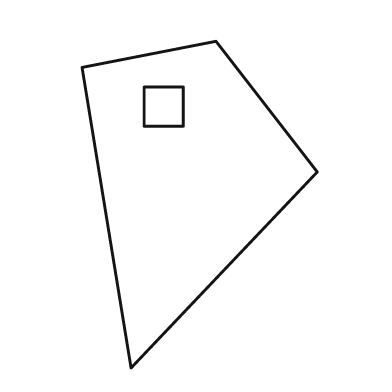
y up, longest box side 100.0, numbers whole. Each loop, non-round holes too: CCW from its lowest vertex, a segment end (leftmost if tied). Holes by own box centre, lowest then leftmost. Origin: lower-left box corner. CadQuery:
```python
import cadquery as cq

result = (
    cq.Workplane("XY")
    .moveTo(15.0, 0.0)
    .lineTo(72.0, 60.0)
    .lineTo(41.0, 100.0)
    .lineTo(0.0, 92.0)
    .close()
    .moveTo(19.0, 74.0)
    .lineTo(31.0, 74.0)
    .lineTo(31.0, 86.0)
    .lineTo(19.0, 86.0)
    .close()
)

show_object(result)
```